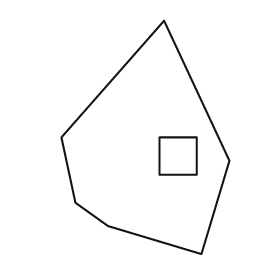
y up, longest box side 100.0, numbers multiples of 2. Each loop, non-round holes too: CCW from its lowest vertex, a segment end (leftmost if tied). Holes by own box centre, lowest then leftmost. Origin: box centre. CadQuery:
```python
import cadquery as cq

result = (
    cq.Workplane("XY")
    .moveTo(24.0, -50.0)
    .lineTo(36.0, -10.0)
    .lineTo(8.0, 50.0)
    .lineTo(-36.0, 0.0)
    .lineTo(-30.0, -28.0)
    .lineTo(-16.0, -38.0)
    .close()
    .moveTo(6.0, -16.0)
    .lineTo(22.0, -16.0)
    .lineTo(22.0, 0.0)
    .lineTo(6.0, 0.0)
    .close()
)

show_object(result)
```